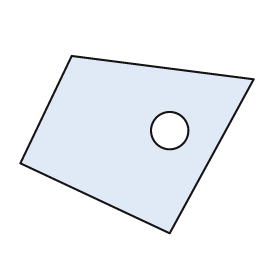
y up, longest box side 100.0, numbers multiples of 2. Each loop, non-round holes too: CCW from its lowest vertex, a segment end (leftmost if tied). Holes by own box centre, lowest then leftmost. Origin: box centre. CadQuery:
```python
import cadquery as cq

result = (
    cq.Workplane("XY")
    .moveTo(14.0, -38.0)
    .lineTo(50.0, 28.0)
    .lineTo(-28.0, 38.0)
    .lineTo(-50.0, -8.0)
    .close()
    .moveTo(14.0, 6.0)
    .circle(8.0)
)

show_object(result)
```